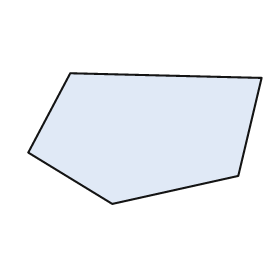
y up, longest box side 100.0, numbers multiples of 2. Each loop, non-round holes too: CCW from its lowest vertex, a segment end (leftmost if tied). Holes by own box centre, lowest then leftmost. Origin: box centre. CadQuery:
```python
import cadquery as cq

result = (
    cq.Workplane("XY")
    .moveTo(-14.0, -28.0)
    .lineTo(40.0, -16.0)
    .lineTo(50.0, 26.0)
    .lineTo(-32.0, 28.0)
    .lineTo(-50.0, -6.0)
    .close()
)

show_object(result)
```